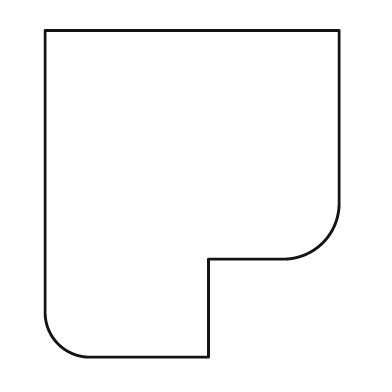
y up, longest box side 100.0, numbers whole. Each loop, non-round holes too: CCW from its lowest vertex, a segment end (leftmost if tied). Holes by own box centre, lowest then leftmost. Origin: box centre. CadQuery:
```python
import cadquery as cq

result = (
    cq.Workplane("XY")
    .moveTo(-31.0, -50.0)
    .lineTo(5.0, -50.0)
    .lineTo(5.0, -20.0)
    .lineTo(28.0, -20.0)
    .threePointArc((40.0, -15.0), (45.0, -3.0))
    .lineTo(45.0, 50.0)
    .lineTo(-45.0, 50.0)
    .lineTo(-45.0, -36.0)
    .threePointArc((-41.0, -46.0), (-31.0, -50.0))
    .close()
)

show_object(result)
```